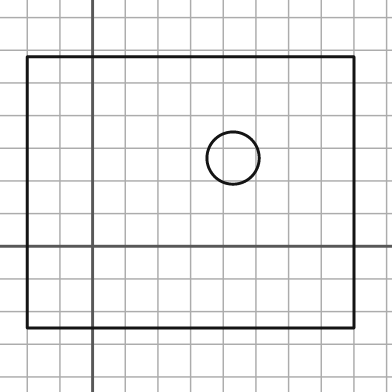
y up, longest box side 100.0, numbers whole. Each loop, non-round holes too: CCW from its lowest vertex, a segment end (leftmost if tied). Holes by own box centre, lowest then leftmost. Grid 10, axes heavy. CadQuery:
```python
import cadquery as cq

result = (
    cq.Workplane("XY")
    .moveTo(-20.0, -25.0)
    .lineTo(80.0, -25.0)
    .lineTo(80.0, 58.0)
    .lineTo(-20.0, 58.0)
    .close()
    .moveTo(43.0, 27.0)
    .circle(8.0)
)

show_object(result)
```